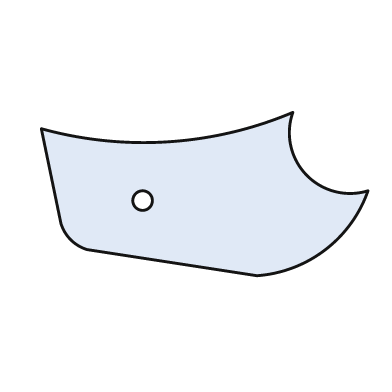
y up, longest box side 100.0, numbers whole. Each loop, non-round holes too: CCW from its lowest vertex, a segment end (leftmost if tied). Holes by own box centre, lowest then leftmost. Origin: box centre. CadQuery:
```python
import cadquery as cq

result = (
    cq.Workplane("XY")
    .moveTo(16.0, -25.0)
    .threePointArc((37.0, -17.0), (50.0, 1.0))
    .threePointArc((31.0, 6.0), (27.0, 25.0))
    .threePointArc((-11.0, 16.0), (-50.0, 20.0))
    .lineTo(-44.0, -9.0)
    .threePointArc((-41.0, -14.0), (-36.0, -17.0))
    .close()
    .moveTo(-19.0, -2.0)
    .circle(3.0)
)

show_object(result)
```